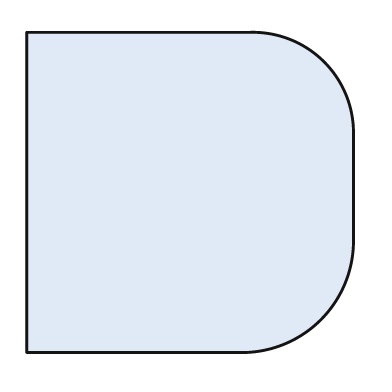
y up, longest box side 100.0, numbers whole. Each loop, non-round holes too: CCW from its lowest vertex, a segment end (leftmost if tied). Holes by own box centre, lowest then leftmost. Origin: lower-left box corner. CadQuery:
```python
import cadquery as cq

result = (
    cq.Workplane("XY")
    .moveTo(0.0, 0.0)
    .lineTo(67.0, 0.0)
    .threePointArc((90.0, 10.0), (100.0, 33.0))
    .lineTo(100.0, 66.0)
    .threePointArc((91.0, 89.0), (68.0, 98.0))
    .lineTo(0.0, 98.0)
    .close()
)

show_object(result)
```